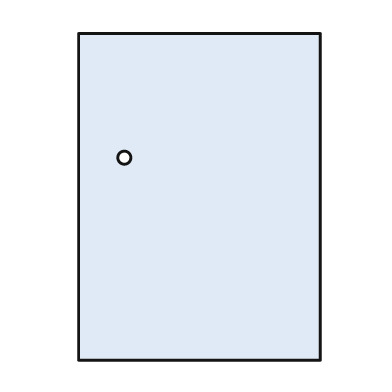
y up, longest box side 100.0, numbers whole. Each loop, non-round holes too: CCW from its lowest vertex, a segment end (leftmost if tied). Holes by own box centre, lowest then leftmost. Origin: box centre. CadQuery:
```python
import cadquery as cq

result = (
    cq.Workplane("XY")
    .moveTo(-37.0, -50.0)
    .lineTo(37.0, -50.0)
    .lineTo(37.0, 50.0)
    .lineTo(-37.0, 50.0)
    .close()
    .moveTo(-23.0, 12.0)
    .circle(2.0)
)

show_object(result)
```